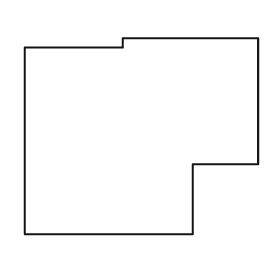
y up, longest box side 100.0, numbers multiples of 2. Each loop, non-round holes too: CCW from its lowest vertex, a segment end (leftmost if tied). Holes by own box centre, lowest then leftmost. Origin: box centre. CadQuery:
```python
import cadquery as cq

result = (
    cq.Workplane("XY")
    .moveTo(-50.0, -42.0)
    .lineTo(22.0, -42.0)
    .lineTo(22.0, -12.0)
    .lineTo(50.0, -12.0)
    .lineTo(50.0, 42.0)
    .lineTo(-8.0, 42.0)
    .lineTo(-8.0, 38.0)
    .lineTo(-50.0, 38.0)
    .close()
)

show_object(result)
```